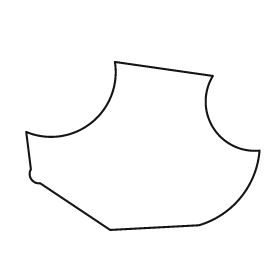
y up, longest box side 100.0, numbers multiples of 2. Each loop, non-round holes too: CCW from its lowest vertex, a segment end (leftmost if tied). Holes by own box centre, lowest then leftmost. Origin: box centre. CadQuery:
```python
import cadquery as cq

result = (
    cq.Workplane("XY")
    .moveTo(-14.0, -36.0)
    .lineTo(24.0, -34.0)
    .threePointArc((42.0, -22.0), (50.0, -2.0))
    .threePointArc((30.0, 8.0), (30.0, 30.0))
    .lineTo(-12.0, 36.0)
    .threePointArc((-22.0, 10.0), (-50.0, 6.0))
    .lineTo(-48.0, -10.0)
    .threePointArc((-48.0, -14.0), (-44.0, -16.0))
    .close()
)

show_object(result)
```